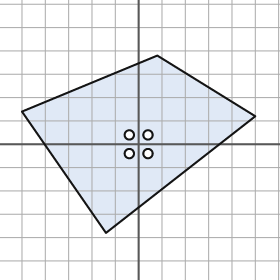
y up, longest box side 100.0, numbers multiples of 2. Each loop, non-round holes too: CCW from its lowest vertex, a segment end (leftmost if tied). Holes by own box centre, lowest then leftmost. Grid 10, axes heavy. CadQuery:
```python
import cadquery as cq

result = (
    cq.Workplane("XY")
    .moveTo(-14.0, -38.0)
    .lineTo(50.0, 12.0)
    .lineTo(8.0, 38.0)
    .lineTo(-50.0, 14.0)
    .close()
    .moveTo(-4.0, -4.0)
    .circle(2.0)
    .moveTo(4.0, -4.0)
    .circle(2.0)
    .moveTo(-4.0, 4.0)
    .circle(2.0)
    .moveTo(4.0, 4.0)
    .circle(2.0)
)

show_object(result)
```